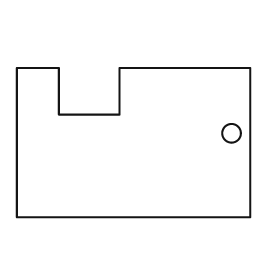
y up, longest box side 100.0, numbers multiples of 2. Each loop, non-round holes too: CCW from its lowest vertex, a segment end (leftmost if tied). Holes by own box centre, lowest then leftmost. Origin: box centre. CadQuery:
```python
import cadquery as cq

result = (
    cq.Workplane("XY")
    .moveTo(-50.0, -32.0)
    .lineTo(50.0, -32.0)
    .lineTo(50.0, 32.0)
    .lineTo(-6.0, 32.0)
    .lineTo(-6.0, 12.0)
    .lineTo(-32.0, 12.0)
    .lineTo(-32.0, 32.0)
    .lineTo(-50.0, 32.0)
    .close()
    .moveTo(42.0, 4.0)
    .circle(4.0)
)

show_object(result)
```